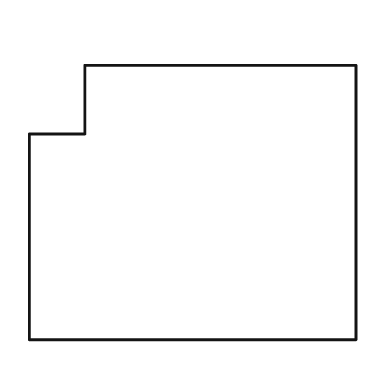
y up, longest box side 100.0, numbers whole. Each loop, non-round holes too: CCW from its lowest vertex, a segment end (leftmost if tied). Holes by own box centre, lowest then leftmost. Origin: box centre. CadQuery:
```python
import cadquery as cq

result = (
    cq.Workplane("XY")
    .moveTo(-50.0, -42.0)
    .lineTo(50.0, -42.0)
    .lineTo(50.0, 42.0)
    .lineTo(-33.0, 42.0)
    .lineTo(-33.0, 21.0)
    .lineTo(-50.0, 21.0)
    .close()
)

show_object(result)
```